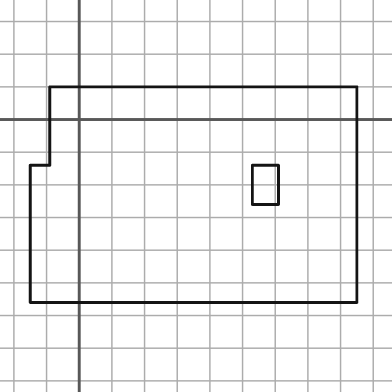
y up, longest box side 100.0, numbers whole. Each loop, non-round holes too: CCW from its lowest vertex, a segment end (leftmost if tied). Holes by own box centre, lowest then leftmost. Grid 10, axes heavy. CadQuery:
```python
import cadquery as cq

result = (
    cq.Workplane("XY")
    .moveTo(-15.0, -56.0)
    .lineTo(85.0, -56.0)
    .lineTo(85.0, 10.0)
    .lineTo(-9.0, 10.0)
    .lineTo(-9.0, -14.0)
    .lineTo(-15.0, -14.0)
    .close()
    .moveTo(53.0, -26.0)
    .lineTo(61.0, -26.0)
    .lineTo(61.0, -14.0)
    .lineTo(53.0, -14.0)
    .close()
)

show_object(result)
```